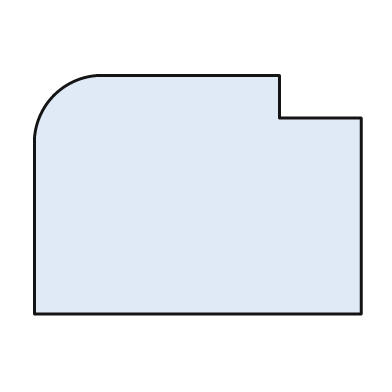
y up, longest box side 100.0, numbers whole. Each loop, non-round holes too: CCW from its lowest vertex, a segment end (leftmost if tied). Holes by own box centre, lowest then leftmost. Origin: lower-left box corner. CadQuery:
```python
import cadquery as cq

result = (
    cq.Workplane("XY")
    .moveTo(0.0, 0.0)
    .lineTo(100.0, 0.0)
    .lineTo(100.0, 60.0)
    .lineTo(75.0, 60.0)
    .lineTo(75.0, 73.0)
    .lineTo(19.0, 73.0)
    .threePointArc((6.0, 67.0), (0.0, 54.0))
    .close()
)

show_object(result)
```